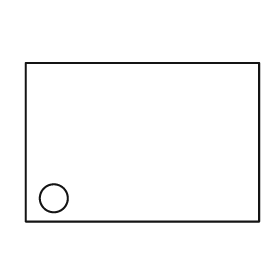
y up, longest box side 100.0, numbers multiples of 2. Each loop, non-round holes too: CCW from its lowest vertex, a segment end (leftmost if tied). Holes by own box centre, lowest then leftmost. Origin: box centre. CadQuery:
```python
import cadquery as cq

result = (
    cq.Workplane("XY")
    .moveTo(-50.0, -34.0)
    .lineTo(50.0, -34.0)
    .lineTo(50.0, 34.0)
    .lineTo(-50.0, 34.0)
    .close()
    .moveTo(-38.0, -24.0)
    .circle(6.0)
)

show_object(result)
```